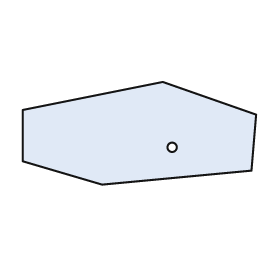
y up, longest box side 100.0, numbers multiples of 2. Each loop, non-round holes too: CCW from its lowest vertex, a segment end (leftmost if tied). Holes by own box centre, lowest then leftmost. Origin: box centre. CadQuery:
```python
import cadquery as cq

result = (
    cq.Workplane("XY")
    .moveTo(-16.0, -22.0)
    .lineTo(48.0, -16.0)
    .lineTo(50.0, 8.0)
    .lineTo(10.0, 22.0)
    .lineTo(-50.0, 10.0)
    .lineTo(-50.0, -12.0)
    .close()
    .moveTo(14.0, -6.0)
    .circle(2.0)
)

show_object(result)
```